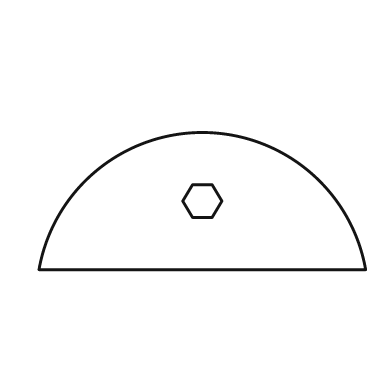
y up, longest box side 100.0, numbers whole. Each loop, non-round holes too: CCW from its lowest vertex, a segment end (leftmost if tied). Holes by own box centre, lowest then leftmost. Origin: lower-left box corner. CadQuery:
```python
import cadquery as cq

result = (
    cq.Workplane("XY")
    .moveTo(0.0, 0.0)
    .lineTo(100.0, 0.0)
    .threePointArc((50.0, 42.0), (0.0, 0.0))
    .close()
    .moveTo(47.0, 16.0)
    .lineTo(53.0, 16.0)
    .lineTo(56.0, 21.0)
    .lineTo(53.0, 26.0)
    .lineTo(47.0, 26.0)
    .lineTo(44.0, 21.0)
    .close()
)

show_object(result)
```